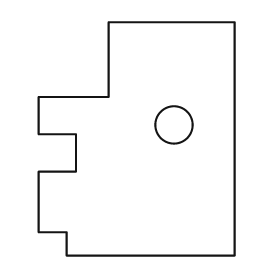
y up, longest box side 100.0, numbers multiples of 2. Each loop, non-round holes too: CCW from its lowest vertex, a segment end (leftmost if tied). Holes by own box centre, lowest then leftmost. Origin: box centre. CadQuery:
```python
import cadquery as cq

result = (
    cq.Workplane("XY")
    .moveTo(-30.0, -50.0)
    .lineTo(42.0, -50.0)
    .lineTo(42.0, 50.0)
    .lineTo(-12.0, 50.0)
    .lineTo(-12.0, 18.0)
    .lineTo(-42.0, 18.0)
    .lineTo(-42.0, 2.0)
    .lineTo(-26.0, 2.0)
    .lineTo(-26.0, -14.0)
    .lineTo(-42.0, -14.0)
    .lineTo(-42.0, -40.0)
    .lineTo(-30.0, -40.0)
    .close()
    .moveTo(16.0, 6.0)
    .circle(8.0)
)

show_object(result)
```